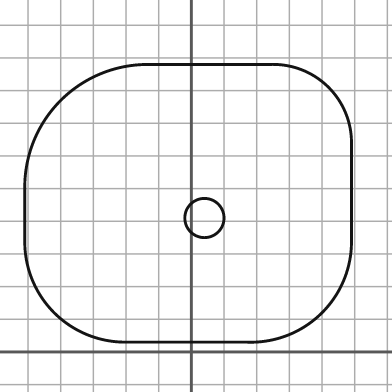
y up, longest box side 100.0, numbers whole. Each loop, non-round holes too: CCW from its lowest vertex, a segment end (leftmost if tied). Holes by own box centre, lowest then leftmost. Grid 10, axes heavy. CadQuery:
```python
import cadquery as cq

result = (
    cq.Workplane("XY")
    .moveTo(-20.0, 3.0)
    .lineTo(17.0, 3.0)
    .threePointArc((40.0, 12.0), (49.0, 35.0))
    .lineTo(49.0, 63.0)
    .threePointArc((42.0, 81.0), (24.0, 88.0))
    .lineTo(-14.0, 88.0)
    .threePointArc((-40.0, 77.0), (-51.0, 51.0))
    .lineTo(-51.0, 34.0)
    .threePointArc((-42.0, 12.0), (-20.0, 3.0))
    .close()
    .moveTo(4.0, 41.0)
    .circle(6.0)
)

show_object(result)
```